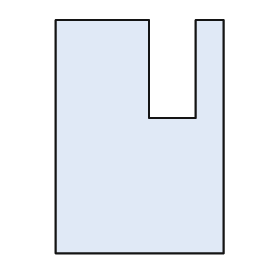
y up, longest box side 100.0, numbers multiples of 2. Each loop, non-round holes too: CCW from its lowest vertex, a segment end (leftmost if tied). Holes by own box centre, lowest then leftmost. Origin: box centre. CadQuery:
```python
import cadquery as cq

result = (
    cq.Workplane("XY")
    .moveTo(-36.0, -50.0)
    .lineTo(36.0, -50.0)
    .lineTo(36.0, 50.0)
    .lineTo(24.0, 50.0)
    .lineTo(24.0, 8.0)
    .lineTo(4.0, 8.0)
    .lineTo(4.0, 50.0)
    .lineTo(-36.0, 50.0)
    .close()
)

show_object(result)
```